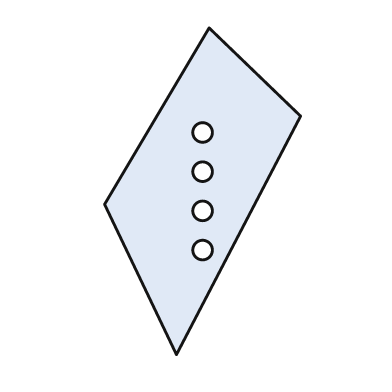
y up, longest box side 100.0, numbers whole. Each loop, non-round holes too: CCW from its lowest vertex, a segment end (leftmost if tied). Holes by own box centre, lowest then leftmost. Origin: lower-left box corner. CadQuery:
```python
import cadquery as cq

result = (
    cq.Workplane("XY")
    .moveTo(22.0, 0.0)
    .lineTo(60.0, 73.0)
    .lineTo(32.0, 100.0)
    .lineTo(0.0, 46.0)
    .close()
    .moveTo(30.0, 32.0)
    .circle(3.0)
    .moveTo(30.0, 44.0)
    .circle(3.0)
    .moveTo(30.0, 56.0)
    .circle(3.0)
    .moveTo(30.0, 68.0)
    .circle(3.0)
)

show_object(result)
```